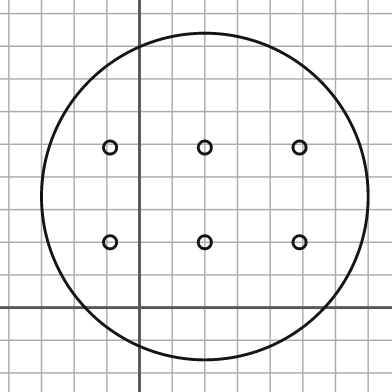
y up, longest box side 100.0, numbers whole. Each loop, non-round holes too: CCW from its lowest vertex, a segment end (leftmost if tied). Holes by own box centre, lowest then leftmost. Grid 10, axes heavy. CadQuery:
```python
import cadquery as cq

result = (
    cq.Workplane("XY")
    .moveTo(20.0, 34.0)
    .circle(50.0)
    .moveTo(-9.0, 20.0)
    .circle(2.0)
    .moveTo(20.0, 20.0)
    .circle(2.0)
    .moveTo(49.0, 20.0)
    .circle(2.0)
    .moveTo(-9.0, 49.0)
    .circle(2.0)
    .moveTo(20.0, 49.0)
    .circle(2.0)
    .moveTo(49.0, 49.0)
    .circle(2.0)
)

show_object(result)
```